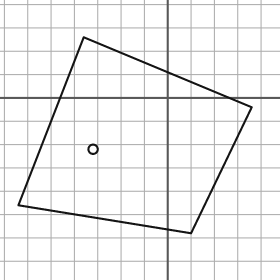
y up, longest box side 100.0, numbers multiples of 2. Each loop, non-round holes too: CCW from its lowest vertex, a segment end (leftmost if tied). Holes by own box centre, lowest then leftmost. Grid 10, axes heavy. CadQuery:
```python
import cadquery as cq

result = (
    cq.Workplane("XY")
    .moveTo(10.0, -58.0)
    .lineTo(36.0, -4.0)
    .lineTo(-36.0, 26.0)
    .lineTo(-64.0, -46.0)
    .close()
    .moveTo(-32.0, -22.0)
    .circle(2.0)
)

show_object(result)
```